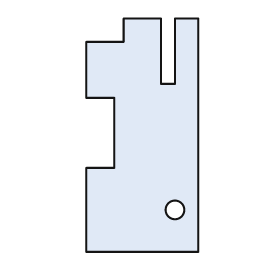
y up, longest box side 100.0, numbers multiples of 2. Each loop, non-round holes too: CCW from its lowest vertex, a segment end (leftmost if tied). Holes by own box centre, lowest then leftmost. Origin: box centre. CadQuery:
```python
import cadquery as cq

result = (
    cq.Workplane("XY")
    .moveTo(-24.0, -50.0)
    .lineTo(24.0, -50.0)
    .lineTo(24.0, 50.0)
    .lineTo(14.0, 50.0)
    .lineTo(14.0, 22.0)
    .lineTo(8.0, 22.0)
    .lineTo(8.0, 50.0)
    .lineTo(-8.0, 50.0)
    .lineTo(-8.0, 40.0)
    .lineTo(-24.0, 40.0)
    .lineTo(-24.0, 16.0)
    .lineTo(-12.0, 16.0)
    .lineTo(-12.0, -14.0)
    .lineTo(-24.0, -14.0)
    .close()
    .moveTo(14.0, -32.0)
    .circle(4.0)
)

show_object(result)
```